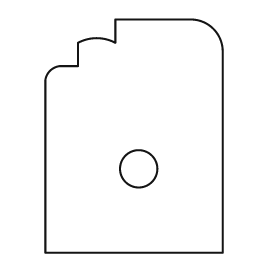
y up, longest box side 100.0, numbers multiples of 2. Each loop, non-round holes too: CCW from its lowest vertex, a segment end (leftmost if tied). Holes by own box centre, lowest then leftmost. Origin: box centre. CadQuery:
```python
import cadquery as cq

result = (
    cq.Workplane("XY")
    .moveTo(-38.0, -50.0)
    .lineTo(38.0, -50.0)
    .lineTo(38.0, 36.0)
    .threePointArc((34.0, 46.0), (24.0, 50.0))
    .lineTo(-8.0, 50.0)
    .lineTo(-8.0, 40.0)
    .threePointArc((-16.0, 42.0), (-24.0, 40.0))
    .lineTo(-24.0, 30.0)
    .lineTo(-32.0, 30.0)
    .threePointArc((-36.0, 28.0), (-38.0, 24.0))
    .close()
    .moveTo(2.0, -14.0)
    .circle(8.0)
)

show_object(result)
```